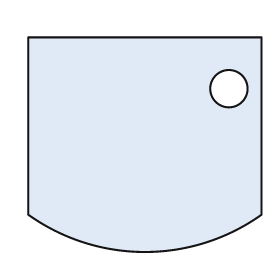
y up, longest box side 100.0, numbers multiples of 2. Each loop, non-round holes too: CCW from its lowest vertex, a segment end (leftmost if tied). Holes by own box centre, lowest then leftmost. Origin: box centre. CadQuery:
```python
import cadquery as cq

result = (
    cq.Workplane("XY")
    .moveTo(-50.0, -30.0)
    .threePointArc((0.0, -46.0), (50.0, -30.0))
    .lineTo(50.0, 46.0)
    .lineTo(-50.0, 46.0)
    .close()
    .moveTo(36.0, 24.0)
    .circle(8.0)
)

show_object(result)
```